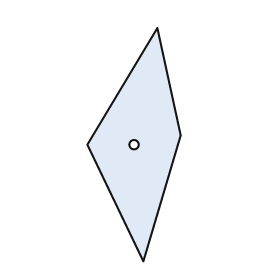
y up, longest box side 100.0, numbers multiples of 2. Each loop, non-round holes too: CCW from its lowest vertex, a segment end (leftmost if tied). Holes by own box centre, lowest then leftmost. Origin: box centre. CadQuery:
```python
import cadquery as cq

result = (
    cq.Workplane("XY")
    .moveTo(4.0, -50.0)
    .lineTo(20.0, 4.0)
    .lineTo(10.0, 50.0)
    .lineTo(-20.0, 0.0)
    .close()
    .moveTo(0.0, 0.0)
    .circle(2.0)
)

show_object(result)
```